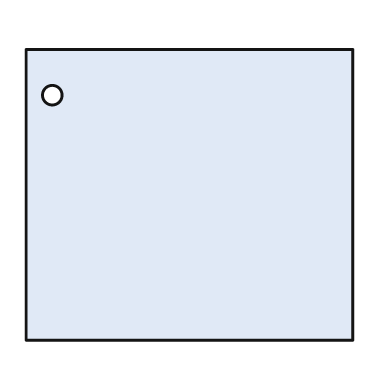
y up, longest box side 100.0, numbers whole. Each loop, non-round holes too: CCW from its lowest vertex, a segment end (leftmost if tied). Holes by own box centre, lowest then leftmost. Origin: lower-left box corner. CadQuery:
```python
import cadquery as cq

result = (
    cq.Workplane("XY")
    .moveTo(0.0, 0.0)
    .lineTo(100.0, 0.0)
    .lineTo(100.0, 89.0)
    .lineTo(0.0, 89.0)
    .close()
    .moveTo(8.0, 75.0)
    .circle(3.0)
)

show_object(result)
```